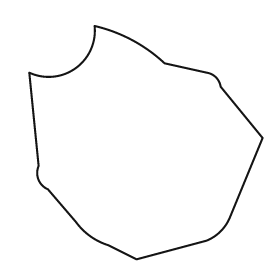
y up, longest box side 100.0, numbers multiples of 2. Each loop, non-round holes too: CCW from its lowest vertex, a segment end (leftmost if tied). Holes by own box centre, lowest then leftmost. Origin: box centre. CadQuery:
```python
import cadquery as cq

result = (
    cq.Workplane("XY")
    .moveTo(-4.0, -50.0)
    .lineTo(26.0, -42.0)
    .threePointArc((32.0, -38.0), (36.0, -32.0))
    .lineTo(50.0, 2.0)
    .lineTo(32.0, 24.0)
    .threePointArc((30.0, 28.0), (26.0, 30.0))
    .lineTo(8.0, 34.0)
    .threePointArc((-6.0, 44.0), (-22.0, 50.0))
    .threePointArc((-30.0, 32.0), (-50.0, 30.0))
    .lineTo(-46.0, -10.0)
    .threePointArc((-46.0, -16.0), (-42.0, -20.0))
    .lineTo(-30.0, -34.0)
    .threePointArc((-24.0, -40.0), (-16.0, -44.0))
    .close()
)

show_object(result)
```